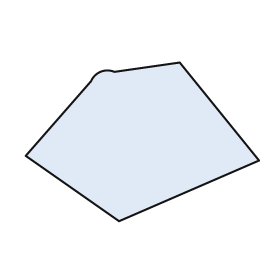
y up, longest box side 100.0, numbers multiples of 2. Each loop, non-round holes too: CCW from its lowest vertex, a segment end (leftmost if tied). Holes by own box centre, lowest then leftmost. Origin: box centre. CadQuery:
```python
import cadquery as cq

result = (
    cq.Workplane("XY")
    .moveTo(-10.0, -34.0)
    .lineTo(50.0, -8.0)
    .lineTo(16.0, 34.0)
    .lineTo(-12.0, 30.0)
    .threePointArc((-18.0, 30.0), (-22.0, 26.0))
    .lineTo(-50.0, -6.0)
    .close()
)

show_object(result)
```